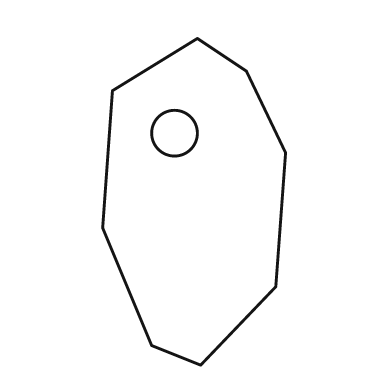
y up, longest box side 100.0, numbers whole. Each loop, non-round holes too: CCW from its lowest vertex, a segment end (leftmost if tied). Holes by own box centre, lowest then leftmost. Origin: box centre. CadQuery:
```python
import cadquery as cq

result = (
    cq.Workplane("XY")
    .moveTo(2.0, -50.0)
    .lineTo(25.0, -26.0)
    .lineTo(28.0, 15.0)
    .lineTo(16.0, 40.0)
    .lineTo(1.0, 50.0)
    .lineTo(-25.0, 34.0)
    .lineTo(-28.0, -8.0)
    .lineTo(-13.0, -44.0)
    .close()
    .moveTo(-6.0, 21.0)
    .circle(7.0)
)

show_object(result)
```